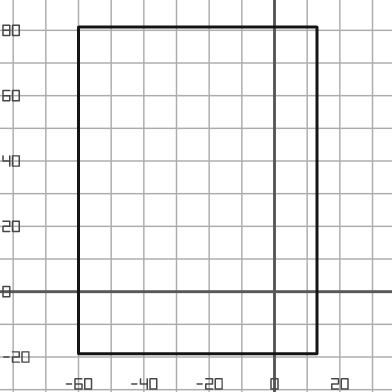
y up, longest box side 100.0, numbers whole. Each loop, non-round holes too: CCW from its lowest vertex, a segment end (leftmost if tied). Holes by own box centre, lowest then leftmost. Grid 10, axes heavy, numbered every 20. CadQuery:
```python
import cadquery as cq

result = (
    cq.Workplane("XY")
    .moveTo(-60.0, -19.0)
    .lineTo(13.0, -19.0)
    .lineTo(13.0, 81.0)
    .lineTo(-60.0, 81.0)
    .close()
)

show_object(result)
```